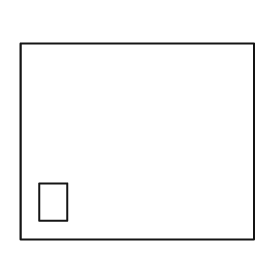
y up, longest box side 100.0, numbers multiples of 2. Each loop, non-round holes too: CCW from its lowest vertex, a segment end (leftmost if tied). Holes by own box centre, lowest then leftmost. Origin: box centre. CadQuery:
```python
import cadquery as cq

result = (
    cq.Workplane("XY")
    .moveTo(-50.0, -42.0)
    .lineTo(50.0, -42.0)
    .lineTo(50.0, 42.0)
    .lineTo(-50.0, 42.0)
    .close()
    .moveTo(-42.0, -34.0)
    .lineTo(-30.0, -34.0)
    .lineTo(-30.0, -18.0)
    .lineTo(-42.0, -18.0)
    .close()
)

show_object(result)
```